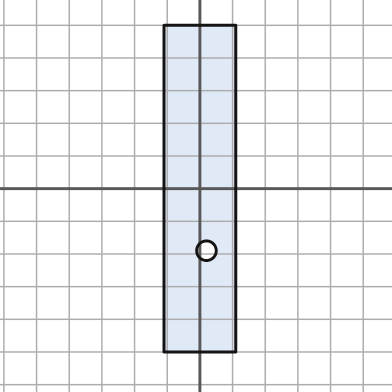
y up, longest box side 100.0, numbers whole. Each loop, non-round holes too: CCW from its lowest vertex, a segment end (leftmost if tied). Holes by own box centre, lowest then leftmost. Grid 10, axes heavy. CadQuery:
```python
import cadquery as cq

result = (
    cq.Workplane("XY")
    .moveTo(-11.0, -50.0)
    .lineTo(11.0, -50.0)
    .lineTo(11.0, 50.0)
    .lineTo(-11.0, 50.0)
    .close()
    .moveTo(2.0, -19.0)
    .circle(3.0)
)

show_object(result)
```